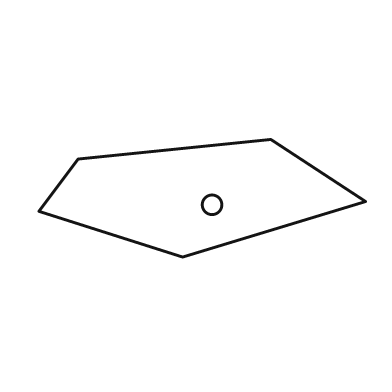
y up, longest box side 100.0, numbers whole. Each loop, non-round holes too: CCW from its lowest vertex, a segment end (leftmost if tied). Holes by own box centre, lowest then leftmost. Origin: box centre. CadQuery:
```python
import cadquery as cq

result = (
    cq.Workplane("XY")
    .moveTo(-6.0, -18.0)
    .lineTo(50.0, -1.0)
    .lineTo(21.0, 18.0)
    .lineTo(-38.0, 12.0)
    .lineTo(-50.0, -4.0)
    .close()
    .moveTo(3.0, -2.0)
    .circle(3.0)
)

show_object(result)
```